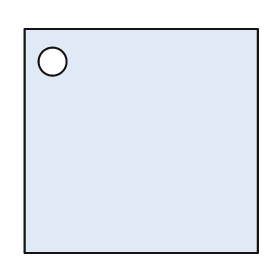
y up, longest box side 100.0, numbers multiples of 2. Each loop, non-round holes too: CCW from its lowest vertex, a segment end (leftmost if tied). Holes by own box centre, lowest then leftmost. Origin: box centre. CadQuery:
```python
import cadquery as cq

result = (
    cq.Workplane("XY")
    .moveTo(-50.0, -48.0)
    .lineTo(50.0, -48.0)
    .lineTo(50.0, 48.0)
    .lineTo(-50.0, 48.0)
    .close()
    .moveTo(-38.0, 34.0)
    .circle(6.0)
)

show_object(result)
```